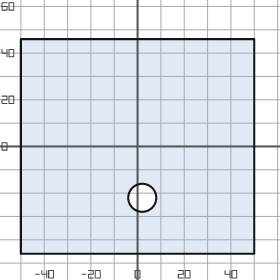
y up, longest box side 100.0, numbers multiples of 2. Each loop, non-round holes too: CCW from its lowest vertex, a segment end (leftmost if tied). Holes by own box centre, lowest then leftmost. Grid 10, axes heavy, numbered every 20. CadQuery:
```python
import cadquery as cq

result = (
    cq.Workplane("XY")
    .moveTo(-50.0, -46.0)
    .lineTo(50.0, -46.0)
    .lineTo(50.0, 46.0)
    .lineTo(-50.0, 46.0)
    .close()
    .moveTo(2.0, -22.0)
    .circle(6.0)
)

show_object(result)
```